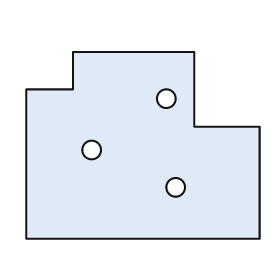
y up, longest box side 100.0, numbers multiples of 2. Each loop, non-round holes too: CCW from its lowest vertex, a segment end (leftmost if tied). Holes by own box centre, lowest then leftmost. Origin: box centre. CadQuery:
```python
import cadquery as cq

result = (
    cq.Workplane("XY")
    .moveTo(-50.0, -40.0)
    .lineTo(50.0, -40.0)
    .lineTo(50.0, 8.0)
    .lineTo(22.0, 8.0)
    .lineTo(22.0, 40.0)
    .lineTo(-30.0, 40.0)
    .lineTo(-30.0, 24.0)
    .lineTo(-50.0, 24.0)
    .close()
    .moveTo(14.0, -18.0)
    .circle(4.0)
    .moveTo(-22.0, -2.0)
    .circle(4.0)
    .moveTo(10.0, 20.0)
    .circle(4.0)
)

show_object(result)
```